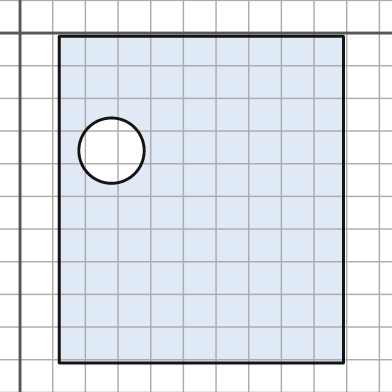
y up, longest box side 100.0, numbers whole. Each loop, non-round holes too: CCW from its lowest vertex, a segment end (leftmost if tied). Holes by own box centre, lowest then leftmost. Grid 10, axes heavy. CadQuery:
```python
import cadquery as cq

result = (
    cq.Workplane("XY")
    .moveTo(12.0, -101.0)
    .lineTo(99.0, -101.0)
    .lineTo(99.0, -1.0)
    .lineTo(12.0, -1.0)
    .close()
    .moveTo(28.0, -36.0)
    .circle(10.0)
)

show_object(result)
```